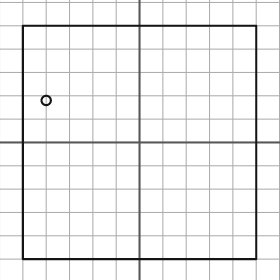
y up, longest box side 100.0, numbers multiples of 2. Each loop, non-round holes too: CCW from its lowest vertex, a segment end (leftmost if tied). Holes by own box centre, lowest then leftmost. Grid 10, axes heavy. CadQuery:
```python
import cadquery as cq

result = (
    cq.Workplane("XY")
    .moveTo(-50.0, -50.0)
    .lineTo(50.0, -50.0)
    .lineTo(50.0, 50.0)
    .lineTo(-50.0, 50.0)
    .close()
    .moveTo(-40.0, 18.0)
    .circle(2.0)
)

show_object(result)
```